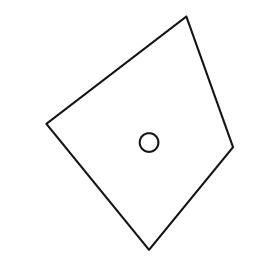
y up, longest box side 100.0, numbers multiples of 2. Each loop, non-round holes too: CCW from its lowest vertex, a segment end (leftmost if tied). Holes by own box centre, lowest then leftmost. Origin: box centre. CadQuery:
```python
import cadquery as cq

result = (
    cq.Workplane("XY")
    .moveTo(4.0, -50.0)
    .lineTo(40.0, -6.0)
    .lineTo(20.0, 50.0)
    .lineTo(-40.0, 4.0)
    .close()
    .moveTo(4.0, -4.0)
    .circle(4.0)
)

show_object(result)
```